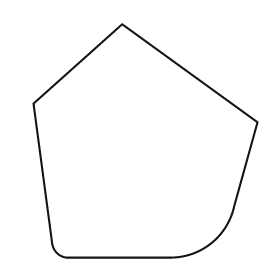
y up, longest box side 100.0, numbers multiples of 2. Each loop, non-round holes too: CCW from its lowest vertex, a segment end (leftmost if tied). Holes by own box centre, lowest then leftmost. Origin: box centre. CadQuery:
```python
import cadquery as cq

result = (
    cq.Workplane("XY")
    .moveTo(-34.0, -50.0)
    .lineTo(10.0, -50.0)
    .threePointArc((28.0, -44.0), (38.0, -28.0))
    .lineTo(48.0, 8.0)
    .lineTo(-10.0, 50.0)
    .lineTo(-48.0, 16.0)
    .lineTo(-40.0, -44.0)
    .threePointArc((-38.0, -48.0), (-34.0, -50.0))
    .close()
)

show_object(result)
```